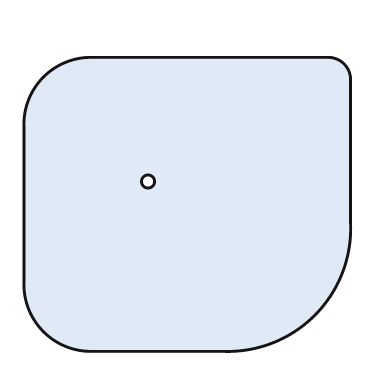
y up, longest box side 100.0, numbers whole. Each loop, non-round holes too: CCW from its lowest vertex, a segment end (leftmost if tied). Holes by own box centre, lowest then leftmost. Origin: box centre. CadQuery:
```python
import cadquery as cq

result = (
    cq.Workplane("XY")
    .moveTo(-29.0, -45.0)
    .lineTo(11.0, -45.0)
    .threePointArc((39.0, -34.0), (50.0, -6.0))
    .lineTo(50.0, 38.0)
    .threePointArc((48.0, 43.0), (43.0, 45.0))
    .lineTo(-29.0, 45.0)
    .threePointArc((-44.0, 39.0), (-50.0, 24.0))
    .lineTo(-50.0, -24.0)
    .threePointArc((-44.0, -39.0), (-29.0, -45.0))
    .close()
    .moveTo(-12.0, 7.0)
    .circle(2.0)
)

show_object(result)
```